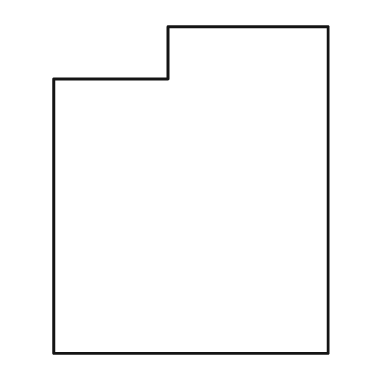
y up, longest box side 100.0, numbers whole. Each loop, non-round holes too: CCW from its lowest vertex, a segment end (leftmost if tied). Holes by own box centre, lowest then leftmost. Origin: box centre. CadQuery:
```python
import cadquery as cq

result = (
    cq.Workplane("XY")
    .moveTo(-42.0, -50.0)
    .lineTo(42.0, -50.0)
    .lineTo(42.0, 50.0)
    .lineTo(-7.0, 50.0)
    .lineTo(-7.0, 34.0)
    .lineTo(-42.0, 34.0)
    .close()
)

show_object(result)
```